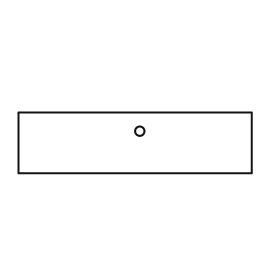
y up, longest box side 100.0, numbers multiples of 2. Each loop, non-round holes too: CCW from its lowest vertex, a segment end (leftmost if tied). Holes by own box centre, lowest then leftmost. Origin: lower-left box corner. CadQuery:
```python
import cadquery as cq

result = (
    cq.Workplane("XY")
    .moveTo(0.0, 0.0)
    .lineTo(100.0, 0.0)
    .lineTo(100.0, 26.0)
    .lineTo(0.0, 26.0)
    .close()
    .moveTo(52.0, 18.0)
    .circle(2.0)
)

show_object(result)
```